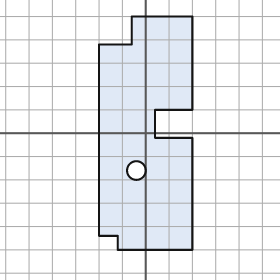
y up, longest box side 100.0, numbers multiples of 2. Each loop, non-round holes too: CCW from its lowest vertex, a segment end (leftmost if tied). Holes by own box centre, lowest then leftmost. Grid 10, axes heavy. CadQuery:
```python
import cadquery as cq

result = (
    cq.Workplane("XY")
    .moveTo(-12.0, -50.0)
    .lineTo(20.0, -50.0)
    .lineTo(20.0, -2.0)
    .lineTo(4.0, -2.0)
    .lineTo(4.0, 10.0)
    .lineTo(20.0, 10.0)
    .lineTo(20.0, 50.0)
    .lineTo(-6.0, 50.0)
    .lineTo(-6.0, 38.0)
    .lineTo(-20.0, 38.0)
    .lineTo(-20.0, -44.0)
    .lineTo(-12.0, -44.0)
    .close()
    .moveTo(-4.0, -16.0)
    .circle(4.0)
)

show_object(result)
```